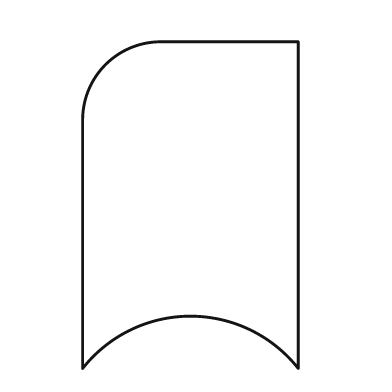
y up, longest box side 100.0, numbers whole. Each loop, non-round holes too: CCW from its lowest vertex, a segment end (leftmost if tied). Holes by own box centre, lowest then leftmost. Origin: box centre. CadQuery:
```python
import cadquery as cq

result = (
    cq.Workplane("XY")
    .moveTo(-33.0, -50.0)
    .threePointArc((0.0, -34.0), (33.0, -50.0))
    .lineTo(33.0, 50.0)
    .lineTo(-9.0, 50.0)
    .threePointArc((-26.0, 43.0), (-33.0, 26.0))
    .close()
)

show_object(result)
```